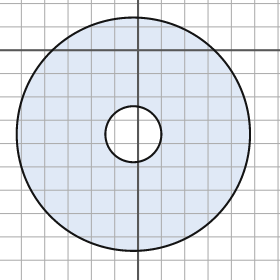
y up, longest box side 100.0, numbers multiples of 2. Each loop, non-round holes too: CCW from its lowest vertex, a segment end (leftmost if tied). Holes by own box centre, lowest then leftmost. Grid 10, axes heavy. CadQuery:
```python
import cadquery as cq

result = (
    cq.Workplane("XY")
    .moveTo(-2.0, -36.0)
    .circle(50.0)
    .moveTo(-2.0, -36.0)
    .circle(12.0)
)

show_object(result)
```